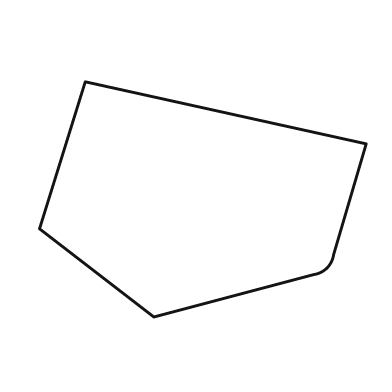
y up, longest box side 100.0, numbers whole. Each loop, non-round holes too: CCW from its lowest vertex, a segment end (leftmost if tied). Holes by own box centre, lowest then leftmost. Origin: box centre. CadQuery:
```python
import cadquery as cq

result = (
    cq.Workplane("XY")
    .moveTo(-15.0, -36.0)
    .lineTo(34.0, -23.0)
    .threePointArc((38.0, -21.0), (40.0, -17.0))
    .lineTo(50.0, 17.0)
    .lineTo(-36.0, 36.0)
    .lineTo(-50.0, -9.0)
    .close()
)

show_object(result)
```